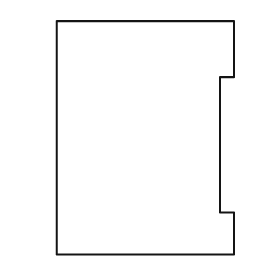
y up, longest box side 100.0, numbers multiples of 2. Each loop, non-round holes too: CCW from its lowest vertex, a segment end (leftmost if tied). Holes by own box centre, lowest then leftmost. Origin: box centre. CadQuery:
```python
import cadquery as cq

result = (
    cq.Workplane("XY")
    .moveTo(-38.0, -50.0)
    .lineTo(38.0, -50.0)
    .lineTo(38.0, -32.0)
    .lineTo(32.0, -32.0)
    .lineTo(32.0, 26.0)
    .lineTo(38.0, 26.0)
    .lineTo(38.0, 50.0)
    .lineTo(-38.0, 50.0)
    .close()
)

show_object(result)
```